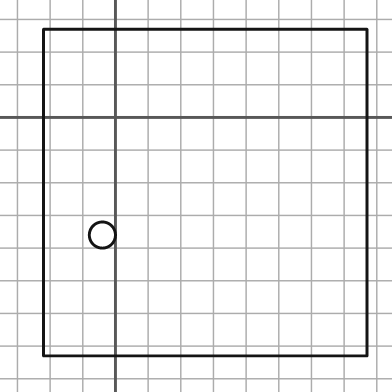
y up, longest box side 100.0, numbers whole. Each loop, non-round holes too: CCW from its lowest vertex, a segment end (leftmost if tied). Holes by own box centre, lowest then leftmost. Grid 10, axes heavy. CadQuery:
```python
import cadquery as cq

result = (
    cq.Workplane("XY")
    .moveTo(-22.0, -73.0)
    .lineTo(77.0, -73.0)
    .lineTo(77.0, 27.0)
    .lineTo(-22.0, 27.0)
    .close()
    .moveTo(-4.0, -36.0)
    .circle(4.0)
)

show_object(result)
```